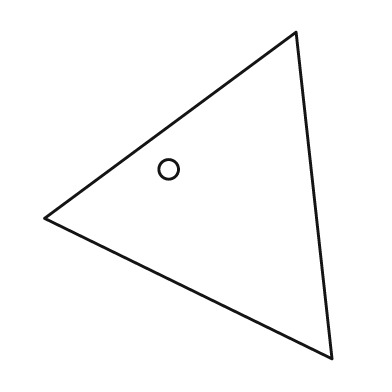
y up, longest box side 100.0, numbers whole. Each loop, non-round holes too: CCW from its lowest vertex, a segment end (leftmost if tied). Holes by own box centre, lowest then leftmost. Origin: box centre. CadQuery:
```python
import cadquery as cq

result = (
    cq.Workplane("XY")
    .moveTo(44.0, -50.0)
    .lineTo(33.0, 50.0)
    .lineTo(-44.0, -7.0)
    .close()
    .moveTo(-6.0, 8.0)
    .circle(3.0)
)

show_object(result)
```